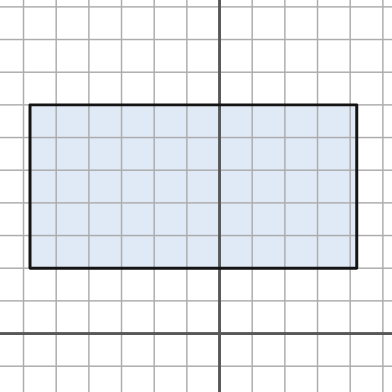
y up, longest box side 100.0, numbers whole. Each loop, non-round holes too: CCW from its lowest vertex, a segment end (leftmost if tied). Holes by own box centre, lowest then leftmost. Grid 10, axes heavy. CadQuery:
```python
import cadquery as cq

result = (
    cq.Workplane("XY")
    .moveTo(-58.0, 20.0)
    .lineTo(42.0, 20.0)
    .lineTo(42.0, 70.0)
    .lineTo(-58.0, 70.0)
    .close()
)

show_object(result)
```